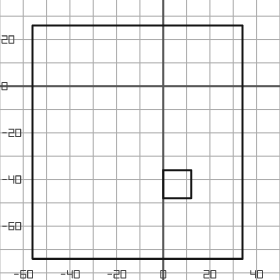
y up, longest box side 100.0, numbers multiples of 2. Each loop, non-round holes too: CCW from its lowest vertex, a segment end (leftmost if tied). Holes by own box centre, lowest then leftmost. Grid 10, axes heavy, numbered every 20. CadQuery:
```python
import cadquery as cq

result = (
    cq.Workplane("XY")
    .moveTo(-56.0, -74.0)
    .lineTo(34.0, -74.0)
    .lineTo(34.0, 26.0)
    .lineTo(-56.0, 26.0)
    .close()
    .moveTo(0.0, -48.0)
    .lineTo(12.0, -48.0)
    .lineTo(12.0, -36.0)
    .lineTo(0.0, -36.0)
    .close()
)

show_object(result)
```